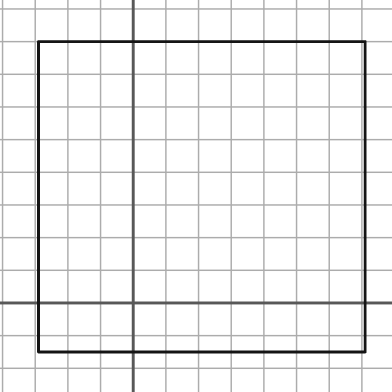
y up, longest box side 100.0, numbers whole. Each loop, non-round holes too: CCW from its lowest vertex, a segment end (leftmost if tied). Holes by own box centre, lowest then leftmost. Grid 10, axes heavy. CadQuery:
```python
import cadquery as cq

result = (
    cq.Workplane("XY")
    .moveTo(-29.0, -15.0)
    .lineTo(71.0, -15.0)
    .lineTo(71.0, 80.0)
    .lineTo(-29.0, 80.0)
    .close()
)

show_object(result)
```